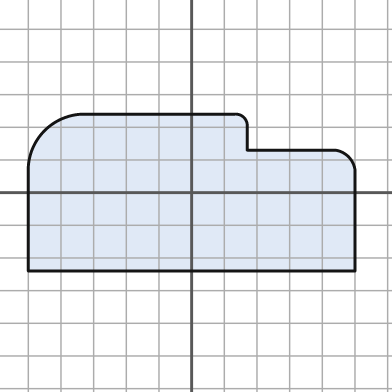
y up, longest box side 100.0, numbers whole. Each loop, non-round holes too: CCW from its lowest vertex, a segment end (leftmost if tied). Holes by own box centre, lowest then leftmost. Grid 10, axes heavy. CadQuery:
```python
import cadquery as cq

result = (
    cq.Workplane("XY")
    .moveTo(-50.0, -24.0)
    .lineTo(50.0, -24.0)
    .lineTo(50.0, 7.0)
    .threePointArc((48.0, 11.0), (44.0, 13.0))
    .lineTo(17.0, 13.0)
    .lineTo(17.0, 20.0)
    .threePointArc((16.0, 23.0), (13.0, 24.0))
    .lineTo(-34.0, 24.0)
    .threePointArc((-45.0, 19.0), (-50.0, 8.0))
    .close()
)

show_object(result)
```